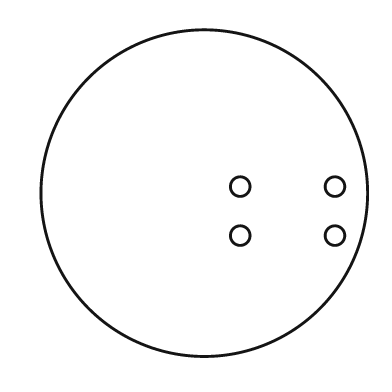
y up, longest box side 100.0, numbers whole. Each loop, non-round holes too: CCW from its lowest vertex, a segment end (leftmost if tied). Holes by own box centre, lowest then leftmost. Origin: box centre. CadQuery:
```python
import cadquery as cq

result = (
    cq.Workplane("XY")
    .moveTo(0.0, 0.0)
    .circle(50.0)
    .moveTo(11.0, -13.0)
    .circle(3.0)
    .moveTo(40.0, -13.0)
    .circle(3.0)
    .moveTo(11.0, 2.0)
    .circle(3.0)
    .moveTo(40.0, 2.0)
    .circle(3.0)
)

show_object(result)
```